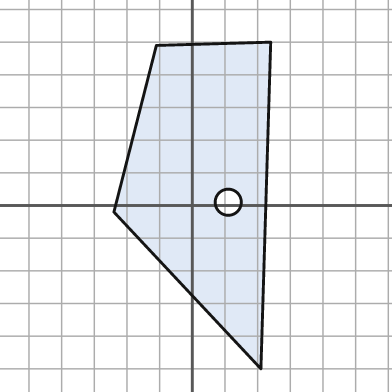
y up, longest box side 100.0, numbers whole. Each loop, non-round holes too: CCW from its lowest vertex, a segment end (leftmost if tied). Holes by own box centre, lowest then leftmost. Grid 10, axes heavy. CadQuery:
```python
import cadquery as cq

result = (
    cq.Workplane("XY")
    .moveTo(21.0, -50.0)
    .lineTo(24.0, 50.0)
    .lineTo(-11.0, 49.0)
    .lineTo(-24.0, -2.0)
    .close()
    .moveTo(11.0, 1.0)
    .circle(4.0)
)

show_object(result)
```